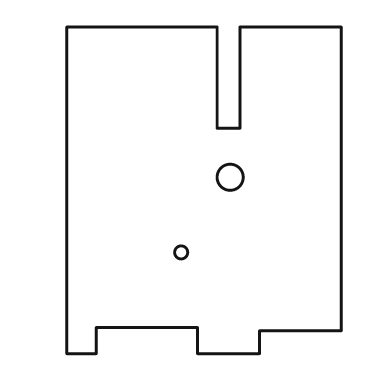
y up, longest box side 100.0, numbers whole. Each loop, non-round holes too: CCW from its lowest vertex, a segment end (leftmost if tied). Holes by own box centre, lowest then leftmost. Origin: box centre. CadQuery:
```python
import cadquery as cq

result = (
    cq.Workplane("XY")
    .moveTo(-42.0, -50.0)
    .lineTo(-33.0, -50.0)
    .lineTo(-33.0, -42.0)
    .lineTo(-2.0, -42.0)
    .lineTo(-2.0, -50.0)
    .lineTo(17.0, -50.0)
    .lineTo(17.0, -43.0)
    .lineTo(42.0, -43.0)
    .lineTo(42.0, 50.0)
    .lineTo(11.0, 50.0)
    .lineTo(11.0, 19.0)
    .lineTo(4.0, 19.0)
    .lineTo(4.0, 50.0)
    .lineTo(-42.0, 50.0)
    .close()
    .moveTo(-7.0, -19.0)
    .circle(2.0)
    .moveTo(8.0, 4.0)
    .circle(4.0)
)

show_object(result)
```